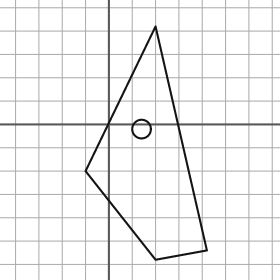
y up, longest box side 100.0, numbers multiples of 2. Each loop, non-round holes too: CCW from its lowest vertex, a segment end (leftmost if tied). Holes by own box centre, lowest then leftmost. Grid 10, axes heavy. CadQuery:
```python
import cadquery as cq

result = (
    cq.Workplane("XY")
    .moveTo(20.0, -58.0)
    .lineTo(42.0, -54.0)
    .lineTo(20.0, 42.0)
    .lineTo(-10.0, -20.0)
    .close()
    .moveTo(14.0, -2.0)
    .circle(4.0)
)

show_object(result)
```